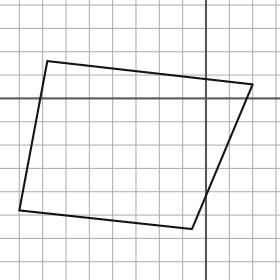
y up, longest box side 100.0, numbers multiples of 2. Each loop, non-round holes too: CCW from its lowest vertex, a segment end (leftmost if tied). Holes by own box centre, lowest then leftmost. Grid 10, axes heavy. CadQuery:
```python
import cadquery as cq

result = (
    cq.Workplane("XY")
    .moveTo(-6.0, -56.0)
    .lineTo(20.0, 6.0)
    .lineTo(-68.0, 16.0)
    .lineTo(-80.0, -48.0)
    .close()
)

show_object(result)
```